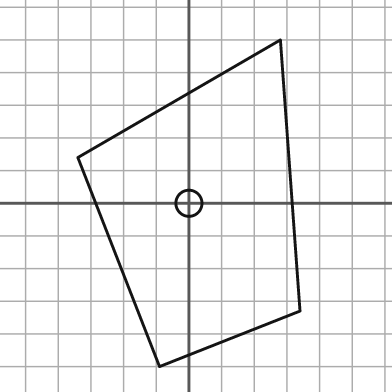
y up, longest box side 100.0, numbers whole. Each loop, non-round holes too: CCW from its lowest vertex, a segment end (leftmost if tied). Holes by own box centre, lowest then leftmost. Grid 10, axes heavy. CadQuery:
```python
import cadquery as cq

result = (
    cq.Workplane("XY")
    .moveTo(-9.0, -50.0)
    .lineTo(34.0, -33.0)
    .lineTo(28.0, 50.0)
    .lineTo(-34.0, 14.0)
    .close()
    .moveTo(0.0, 0.0)
    .circle(4.0)
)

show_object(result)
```